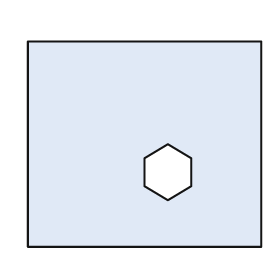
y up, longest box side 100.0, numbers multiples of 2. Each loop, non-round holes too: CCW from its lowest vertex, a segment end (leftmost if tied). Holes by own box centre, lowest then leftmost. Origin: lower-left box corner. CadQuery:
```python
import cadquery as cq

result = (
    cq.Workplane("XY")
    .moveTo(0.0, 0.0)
    .lineTo(100.0, 0.0)
    .lineTo(100.0, 88.0)
    .lineTo(0.0, 88.0)
    .close()
    .moveTo(60.0, 20.0)
    .lineTo(70.0, 26.0)
    .lineTo(70.0, 38.0)
    .lineTo(60.0, 44.0)
    .lineTo(50.0, 38.0)
    .lineTo(50.0, 26.0)
    .close()
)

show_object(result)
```